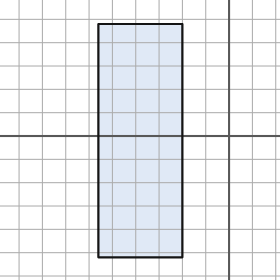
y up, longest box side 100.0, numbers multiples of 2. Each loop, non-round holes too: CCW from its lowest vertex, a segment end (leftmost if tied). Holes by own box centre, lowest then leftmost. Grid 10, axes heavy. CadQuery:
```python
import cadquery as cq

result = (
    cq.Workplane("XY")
    .moveTo(-56.0, -52.0)
    .lineTo(-20.0, -52.0)
    .lineTo(-20.0, 48.0)
    .lineTo(-56.0, 48.0)
    .close()
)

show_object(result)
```